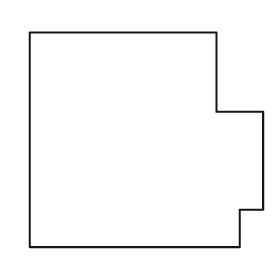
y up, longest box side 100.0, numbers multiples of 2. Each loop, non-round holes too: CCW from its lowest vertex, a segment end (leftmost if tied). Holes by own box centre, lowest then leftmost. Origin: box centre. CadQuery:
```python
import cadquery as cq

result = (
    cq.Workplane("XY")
    .moveTo(-50.0, -46.0)
    .lineTo(40.0, -46.0)
    .lineTo(40.0, -30.0)
    .lineTo(50.0, -30.0)
    .lineTo(50.0, 12.0)
    .lineTo(30.0, 12.0)
    .lineTo(30.0, 46.0)
    .lineTo(-50.0, 46.0)
    .close()
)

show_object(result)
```